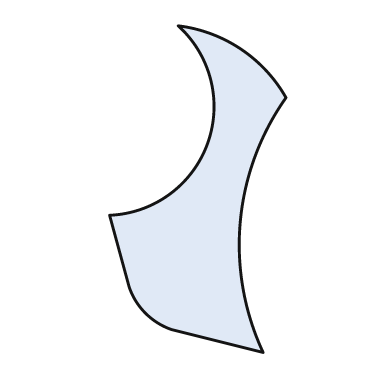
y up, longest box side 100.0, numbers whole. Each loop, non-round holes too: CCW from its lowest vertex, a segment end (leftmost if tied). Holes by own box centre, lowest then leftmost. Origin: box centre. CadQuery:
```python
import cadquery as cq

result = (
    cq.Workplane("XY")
    .moveTo(20.0, -50.0)
    .threePointArc((13.0, -10.0), (27.0, 28.0))
    .threePointArc((13.0, 43.0), (-6.0, 50.0))
    .threePointArc((3.0, 14.0), (-27.0, -8.0))
    .lineTo(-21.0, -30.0)
    .threePointArc((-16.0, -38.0), (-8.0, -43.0))
    .close()
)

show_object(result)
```